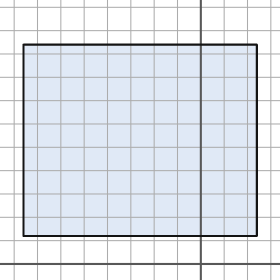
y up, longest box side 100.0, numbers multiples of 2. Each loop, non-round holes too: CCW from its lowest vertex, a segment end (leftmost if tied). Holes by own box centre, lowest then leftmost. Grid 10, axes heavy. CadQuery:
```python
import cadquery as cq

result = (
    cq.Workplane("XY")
    .moveTo(-76.0, 12.0)
    .lineTo(24.0, 12.0)
    .lineTo(24.0, 94.0)
    .lineTo(-76.0, 94.0)
    .close()
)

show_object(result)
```